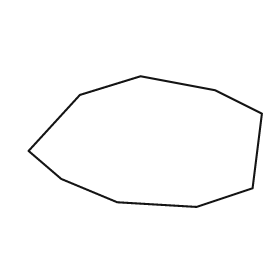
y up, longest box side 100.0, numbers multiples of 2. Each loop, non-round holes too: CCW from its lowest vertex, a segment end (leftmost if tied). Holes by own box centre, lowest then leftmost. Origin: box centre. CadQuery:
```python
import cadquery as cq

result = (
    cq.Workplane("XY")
    .moveTo(22.0, -28.0)
    .lineTo(46.0, -20.0)
    .lineTo(50.0, 12.0)
    .lineTo(30.0, 22.0)
    .lineTo(-2.0, 28.0)
    .lineTo(-28.0, 20.0)
    .lineTo(-50.0, -4.0)
    .lineTo(-36.0, -16.0)
    .lineTo(-12.0, -26.0)
    .close()
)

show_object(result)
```